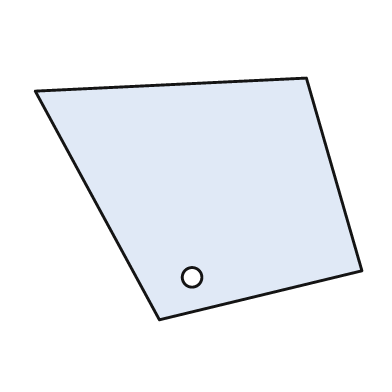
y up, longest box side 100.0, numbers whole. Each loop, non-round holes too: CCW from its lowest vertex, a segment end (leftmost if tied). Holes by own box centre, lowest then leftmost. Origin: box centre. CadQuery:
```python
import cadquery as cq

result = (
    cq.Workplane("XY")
    .moveTo(-12.0, -37.0)
    .lineTo(50.0, -22.0)
    .lineTo(33.0, 37.0)
    .lineTo(-50.0, 33.0)
    .close()
    .moveTo(-2.0, -24.0)
    .circle(3.0)
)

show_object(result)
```